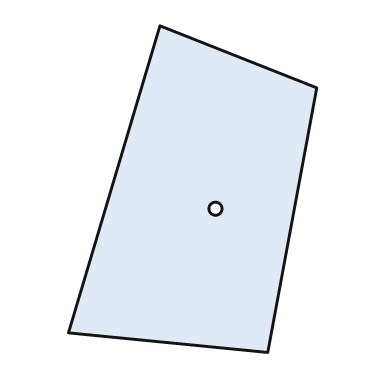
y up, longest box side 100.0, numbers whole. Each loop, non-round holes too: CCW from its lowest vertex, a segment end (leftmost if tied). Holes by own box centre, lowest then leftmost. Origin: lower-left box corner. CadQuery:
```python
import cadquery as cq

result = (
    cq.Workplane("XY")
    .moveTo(61.0, 0.0)
    .lineTo(76.0, 81.0)
    .lineTo(28.0, 100.0)
    .lineTo(0.0, 6.0)
    .close()
    .moveTo(45.0, 44.0)
    .circle(2.0)
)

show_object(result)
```